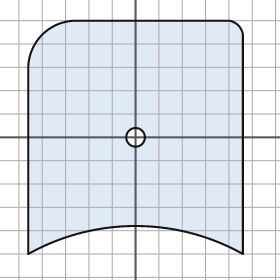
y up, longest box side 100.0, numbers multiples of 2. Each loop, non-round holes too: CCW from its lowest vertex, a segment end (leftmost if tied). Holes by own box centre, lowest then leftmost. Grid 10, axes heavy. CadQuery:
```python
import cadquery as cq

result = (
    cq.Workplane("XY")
    .moveTo(-46.0, -50.0)
    .threePointArc((0.0, -38.0), (46.0, -50.0))
    .lineTo(46.0, 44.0)
    .threePointArc((44.0, 48.0), (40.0, 50.0))
    .lineTo(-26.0, 50.0)
    .threePointArc((-40.0, 44.0), (-46.0, 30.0))
    .close()
    .moveTo(0.0, 0.0)
    .circle(4.0)
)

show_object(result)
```